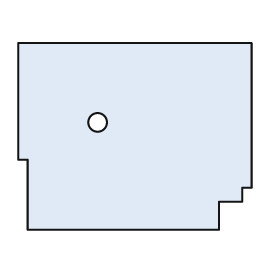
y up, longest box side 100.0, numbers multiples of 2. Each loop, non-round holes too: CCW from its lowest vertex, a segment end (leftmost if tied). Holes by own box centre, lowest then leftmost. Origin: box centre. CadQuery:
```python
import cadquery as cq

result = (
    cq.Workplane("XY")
    .moveTo(-46.0, -40.0)
    .lineTo(36.0, -40.0)
    .lineTo(36.0, -28.0)
    .lineTo(46.0, -28.0)
    .lineTo(46.0, -22.0)
    .lineTo(50.0, -22.0)
    .lineTo(50.0, 40.0)
    .lineTo(-50.0, 40.0)
    .lineTo(-50.0, -10.0)
    .lineTo(-46.0, -10.0)
    .close()
    .moveTo(-16.0, 6.0)
    .circle(4.0)
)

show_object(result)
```